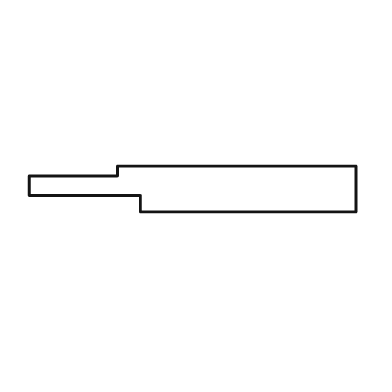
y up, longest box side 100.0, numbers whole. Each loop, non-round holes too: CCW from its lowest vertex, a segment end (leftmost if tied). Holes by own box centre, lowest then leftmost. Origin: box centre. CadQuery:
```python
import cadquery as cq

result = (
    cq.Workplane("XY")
    .moveTo(-16.0, -7.0)
    .lineTo(50.0, -7.0)
    .lineTo(50.0, 7.0)
    .lineTo(-23.0, 7.0)
    .lineTo(-23.0, 4.0)
    .lineTo(-50.0, 4.0)
    .lineTo(-50.0, -2.0)
    .lineTo(-16.0, -2.0)
    .close()
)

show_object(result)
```